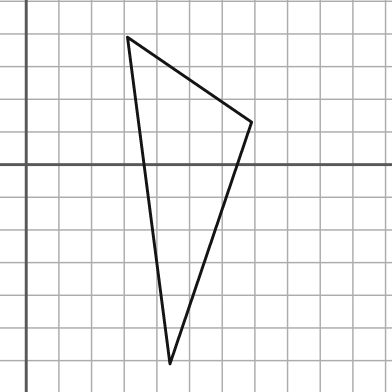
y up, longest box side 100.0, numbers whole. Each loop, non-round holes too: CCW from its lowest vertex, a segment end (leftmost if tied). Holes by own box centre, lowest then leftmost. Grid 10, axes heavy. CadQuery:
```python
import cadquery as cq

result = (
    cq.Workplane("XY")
    .moveTo(44.0, -61.0)
    .lineTo(69.0, 13.0)
    .lineTo(31.0, 39.0)
    .close()
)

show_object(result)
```